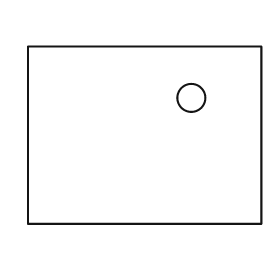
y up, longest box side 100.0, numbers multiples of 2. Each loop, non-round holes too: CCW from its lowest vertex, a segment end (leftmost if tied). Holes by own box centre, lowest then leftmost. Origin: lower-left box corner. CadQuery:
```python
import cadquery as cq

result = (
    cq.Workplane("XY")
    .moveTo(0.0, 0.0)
    .lineTo(100.0, 0.0)
    .lineTo(100.0, 76.0)
    .lineTo(0.0, 76.0)
    .close()
    .moveTo(70.0, 54.0)
    .circle(6.0)
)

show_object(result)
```